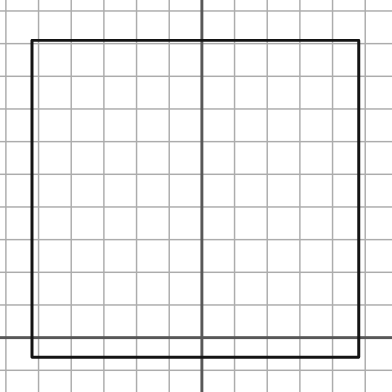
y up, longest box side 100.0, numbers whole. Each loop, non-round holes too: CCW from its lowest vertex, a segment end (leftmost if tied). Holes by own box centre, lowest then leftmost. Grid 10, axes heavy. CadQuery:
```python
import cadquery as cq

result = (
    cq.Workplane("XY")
    .moveTo(-52.0, -6.0)
    .lineTo(48.0, -6.0)
    .lineTo(48.0, 91.0)
    .lineTo(-52.0, 91.0)
    .close()
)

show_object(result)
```